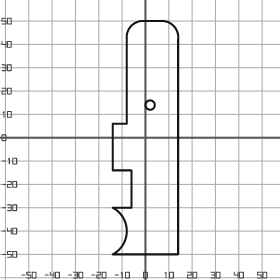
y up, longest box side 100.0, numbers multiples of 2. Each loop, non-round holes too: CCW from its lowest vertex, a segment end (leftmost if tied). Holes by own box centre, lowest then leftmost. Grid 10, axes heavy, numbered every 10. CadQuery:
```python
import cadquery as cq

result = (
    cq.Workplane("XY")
    .moveTo(-14.0, -50.0)
    .lineTo(14.0, -50.0)
    .lineTo(14.0, 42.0)
    .threePointArc((12.0, 48.0), (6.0, 50.0))
    .lineTo(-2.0, 50.0)
    .threePointArc((-6.0, 48.0), (-8.0, 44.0))
    .lineTo(-8.0, 6.0)
    .lineTo(-14.0, 6.0)
    .lineTo(-14.0, -14.0)
    .lineTo(-6.0, -14.0)
    .lineTo(-6.0, -30.0)
    .lineTo(-14.0, -30.0)
    .threePointArc((-8.0, -40.0), (-14.0, -50.0))
    .close()
    .moveTo(2.0, 14.0)
    .circle(2.0)
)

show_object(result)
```